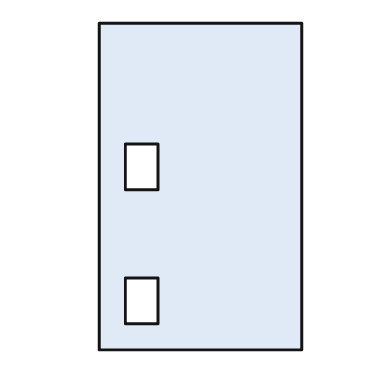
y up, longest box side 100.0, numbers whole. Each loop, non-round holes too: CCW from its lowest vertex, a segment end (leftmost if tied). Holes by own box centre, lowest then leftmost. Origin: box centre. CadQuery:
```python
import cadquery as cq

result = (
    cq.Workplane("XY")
    .moveTo(-31.0, -50.0)
    .lineTo(31.0, -50.0)
    .lineTo(31.0, 50.0)
    .lineTo(-31.0, 50.0)
    .close()
    .moveTo(-23.0, -42.0)
    .lineTo(-13.0, -42.0)
    .lineTo(-13.0, -28.0)
    .lineTo(-23.0, -28.0)
    .close()
    .moveTo(-23.0, -1.0)
    .lineTo(-13.0, -1.0)
    .lineTo(-13.0, 13.0)
    .lineTo(-23.0, 13.0)
    .close()
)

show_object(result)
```